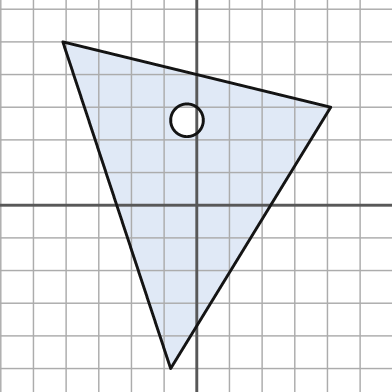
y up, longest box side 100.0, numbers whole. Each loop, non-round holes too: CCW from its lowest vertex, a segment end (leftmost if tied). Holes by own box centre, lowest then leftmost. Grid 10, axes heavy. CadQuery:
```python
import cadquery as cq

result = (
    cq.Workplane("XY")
    .moveTo(-8.0, -50.0)
    .lineTo(41.0, 30.0)
    .lineTo(-41.0, 50.0)
    .close()
    .moveTo(-3.0, 26.0)
    .circle(5.0)
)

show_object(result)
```